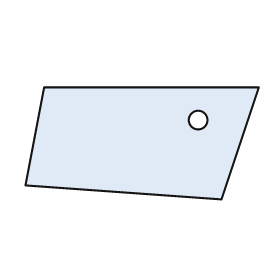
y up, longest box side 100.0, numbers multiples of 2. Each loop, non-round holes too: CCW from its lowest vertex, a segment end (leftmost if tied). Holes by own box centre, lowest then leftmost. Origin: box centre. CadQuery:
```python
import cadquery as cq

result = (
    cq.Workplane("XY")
    .moveTo(34.0, -24.0)
    .lineTo(50.0, 24.0)
    .lineTo(-42.0, 24.0)
    .lineTo(-50.0, -18.0)
    .close()
    .moveTo(24.0, 10.0)
    .circle(4.0)
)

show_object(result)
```